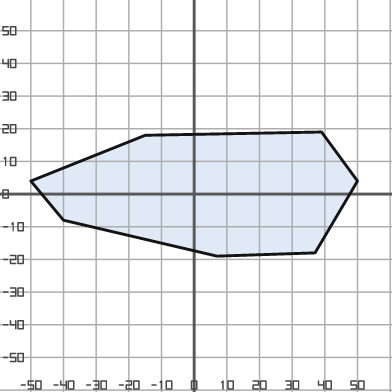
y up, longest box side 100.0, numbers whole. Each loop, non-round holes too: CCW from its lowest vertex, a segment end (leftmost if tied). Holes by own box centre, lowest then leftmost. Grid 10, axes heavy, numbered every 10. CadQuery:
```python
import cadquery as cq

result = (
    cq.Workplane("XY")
    .moveTo(7.0, -19.0)
    .lineTo(37.0, -18.0)
    .lineTo(50.0, 4.0)
    .lineTo(39.0, 19.0)
    .lineTo(-15.0, 18.0)
    .lineTo(-50.0, 4.0)
    .lineTo(-40.0, -8.0)
    .close()
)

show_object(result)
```